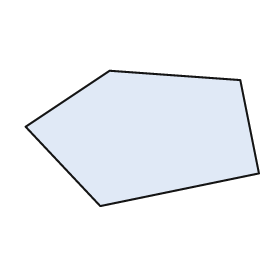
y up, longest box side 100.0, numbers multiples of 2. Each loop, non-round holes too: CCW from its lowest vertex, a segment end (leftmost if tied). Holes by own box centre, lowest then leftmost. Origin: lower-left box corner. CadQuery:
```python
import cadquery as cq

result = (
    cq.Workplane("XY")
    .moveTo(32.0, 0.0)
    .lineTo(100.0, 14.0)
    .lineTo(92.0, 54.0)
    .lineTo(36.0, 58.0)
    .lineTo(0.0, 34.0)
    .close()
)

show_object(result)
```